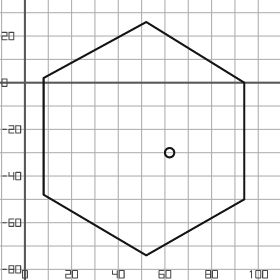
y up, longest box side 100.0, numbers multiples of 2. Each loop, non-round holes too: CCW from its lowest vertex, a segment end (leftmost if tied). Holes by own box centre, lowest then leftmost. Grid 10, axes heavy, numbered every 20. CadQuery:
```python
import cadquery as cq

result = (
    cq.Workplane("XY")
    .moveTo(52.0, -74.0)
    .lineTo(94.0, -50.0)
    .lineTo(94.0, 0.0)
    .lineTo(52.0, 26.0)
    .lineTo(8.0, 2.0)
    .lineTo(8.0, -48.0)
    .close()
    .moveTo(62.0, -30.0)
    .circle(2.0)
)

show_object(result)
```